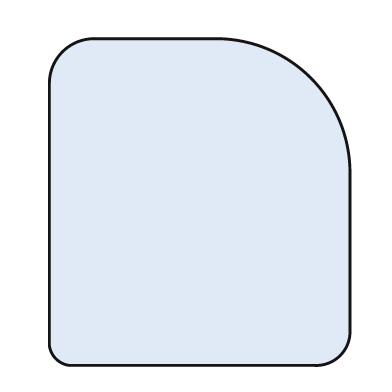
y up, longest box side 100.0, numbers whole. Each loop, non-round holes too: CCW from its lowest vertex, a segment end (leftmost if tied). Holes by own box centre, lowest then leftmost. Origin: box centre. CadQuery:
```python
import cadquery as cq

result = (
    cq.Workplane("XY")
    .moveTo(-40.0, -50.0)
    .lineTo(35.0, -50.0)
    .threePointArc((43.0, -47.0), (46.0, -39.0))
    .lineTo(46.0, 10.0)
    .threePointArc((34.0, 38.0), (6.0, 50.0))
    .lineTo(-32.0, 50.0)
    .threePointArc((-42.0, 46.0), (-46.0, 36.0))
    .lineTo(-46.0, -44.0)
    .threePointArc((-44.0, -48.0), (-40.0, -50.0))
    .close()
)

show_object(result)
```